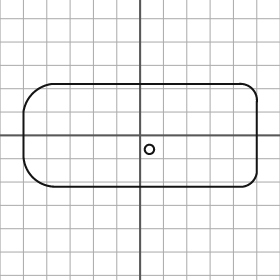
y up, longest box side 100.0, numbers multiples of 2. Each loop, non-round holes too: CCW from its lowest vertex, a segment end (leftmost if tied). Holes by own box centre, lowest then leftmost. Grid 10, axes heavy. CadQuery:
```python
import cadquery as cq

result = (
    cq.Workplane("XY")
    .moveTo(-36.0, -22.0)
    .lineTo(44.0, -22.0)
    .threePointArc((48.0, -20.0), (50.0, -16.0))
    .lineTo(50.0, 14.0)
    .threePointArc((48.0, 20.0), (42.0, 22.0))
    .lineTo(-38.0, 22.0)
    .threePointArc((-46.0, 18.0), (-50.0, 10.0))
    .lineTo(-50.0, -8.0)
    .threePointArc((-46.0, -18.0), (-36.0, -22.0))
    .close()
    .moveTo(4.0, -6.0)
    .circle(2.0)
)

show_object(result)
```